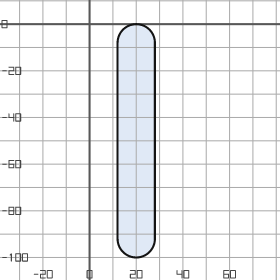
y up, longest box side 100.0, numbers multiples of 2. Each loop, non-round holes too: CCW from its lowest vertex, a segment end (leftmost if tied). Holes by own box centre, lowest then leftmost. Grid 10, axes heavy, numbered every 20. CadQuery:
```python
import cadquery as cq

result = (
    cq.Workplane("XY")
    .moveTo(12.0, -92.0)
    .threePointArc((20.0, -100.0), (28.0, -92.0))
    .lineTo(28.0, -8.0)
    .threePointArc((20.0, 0.0), (12.0, -8.0))
    .close()
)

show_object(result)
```